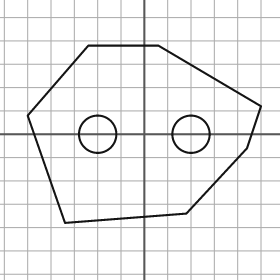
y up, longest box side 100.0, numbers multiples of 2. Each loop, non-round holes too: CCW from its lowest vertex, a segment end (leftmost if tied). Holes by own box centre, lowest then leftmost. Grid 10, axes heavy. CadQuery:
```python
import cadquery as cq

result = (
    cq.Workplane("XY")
    .moveTo(-34.0, -38.0)
    .lineTo(18.0, -34.0)
    .lineTo(44.0, -6.0)
    .lineTo(50.0, 12.0)
    .lineTo(6.0, 38.0)
    .lineTo(-24.0, 38.0)
    .lineTo(-50.0, 8.0)
    .close()
    .moveTo(-20.0, 0.0)
    .circle(8.0)
    .moveTo(20.0, 0.0)
    .circle(8.0)
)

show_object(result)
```